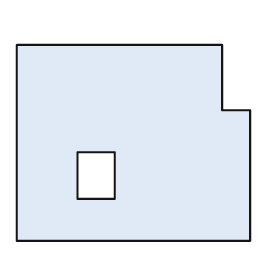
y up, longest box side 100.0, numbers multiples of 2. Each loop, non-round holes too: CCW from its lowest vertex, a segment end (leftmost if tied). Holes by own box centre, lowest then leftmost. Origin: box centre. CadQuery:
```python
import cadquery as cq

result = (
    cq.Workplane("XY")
    .moveTo(-50.0, -42.0)
    .lineTo(50.0, -42.0)
    .lineTo(50.0, 14.0)
    .lineTo(38.0, 14.0)
    .lineTo(38.0, 42.0)
    .lineTo(-50.0, 42.0)
    .close()
    .moveTo(-24.0, -24.0)
    .lineTo(-8.0, -24.0)
    .lineTo(-8.0, -4.0)
    .lineTo(-24.0, -4.0)
    .close()
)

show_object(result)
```